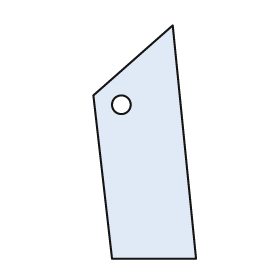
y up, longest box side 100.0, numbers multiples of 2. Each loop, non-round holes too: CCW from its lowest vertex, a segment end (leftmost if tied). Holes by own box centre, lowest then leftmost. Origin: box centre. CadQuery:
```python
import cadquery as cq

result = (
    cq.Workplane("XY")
    .moveTo(-14.0, -50.0)
    .lineTo(22.0, -50.0)
    .lineTo(12.0, 50.0)
    .lineTo(-22.0, 20.0)
    .close()
    .moveTo(-10.0, 16.0)
    .circle(4.0)
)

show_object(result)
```